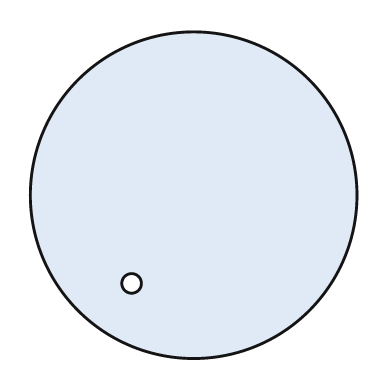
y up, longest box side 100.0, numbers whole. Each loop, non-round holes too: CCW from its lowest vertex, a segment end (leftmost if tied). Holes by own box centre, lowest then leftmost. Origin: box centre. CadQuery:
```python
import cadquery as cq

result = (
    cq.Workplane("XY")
    .moveTo(0.0, 0.0)
    .circle(50.0)
    .moveTo(-19.0, -27.0)
    .circle(3.0)
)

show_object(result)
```